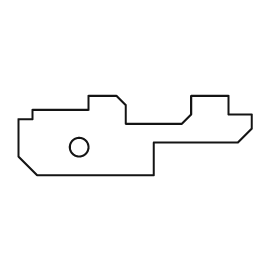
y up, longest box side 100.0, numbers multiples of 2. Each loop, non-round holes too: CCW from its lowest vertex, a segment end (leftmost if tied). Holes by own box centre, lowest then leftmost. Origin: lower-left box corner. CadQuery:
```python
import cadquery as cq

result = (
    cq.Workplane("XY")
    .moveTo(8.0, 0.0)
    .lineTo(58.0, 0.0)
    .lineTo(58.0, 14.0)
    .lineTo(94.0, 14.0)
    .lineTo(100.0, 20.0)
    .lineTo(100.0, 26.0)
    .lineTo(90.0, 26.0)
    .lineTo(90.0, 34.0)
    .lineTo(74.0, 34.0)
    .lineTo(74.0, 26.0)
    .lineTo(70.0, 22.0)
    .lineTo(46.0, 22.0)
    .lineTo(46.0, 30.0)
    .lineTo(42.0, 34.0)
    .lineTo(30.0, 34.0)
    .lineTo(30.0, 28.0)
    .lineTo(6.0, 28.0)
    .lineTo(6.0, 24.0)
    .lineTo(0.0, 24.0)
    .lineTo(0.0, 8.0)
    .close()
    .moveTo(26.0, 12.0)
    .circle(4.0)
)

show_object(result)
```